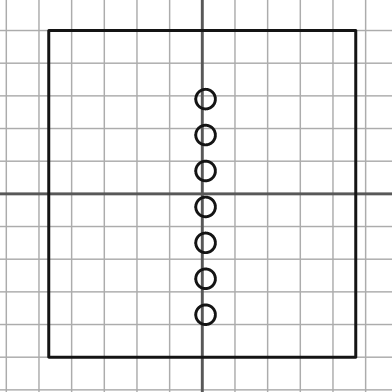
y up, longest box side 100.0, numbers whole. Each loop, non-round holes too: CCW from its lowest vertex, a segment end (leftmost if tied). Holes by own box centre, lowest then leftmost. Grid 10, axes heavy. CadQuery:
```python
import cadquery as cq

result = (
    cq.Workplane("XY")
    .moveTo(-47.0, -50.0)
    .lineTo(47.0, -50.0)
    .lineTo(47.0, 50.0)
    .lineTo(-47.0, 50.0)
    .close()
    .moveTo(1.0, -37.0)
    .circle(3.0)
    .moveTo(1.0, -26.0)
    .circle(3.0)
    .moveTo(1.0, -15.0)
    .circle(3.0)
    .moveTo(1.0, -4.0)
    .circle(3.0)
    .moveTo(1.0, 7.0)
    .circle(3.0)
    .moveTo(1.0, 18.0)
    .circle(3.0)
    .moveTo(1.0, 29.0)
    .circle(3.0)
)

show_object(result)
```